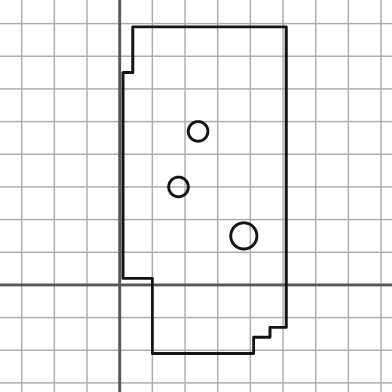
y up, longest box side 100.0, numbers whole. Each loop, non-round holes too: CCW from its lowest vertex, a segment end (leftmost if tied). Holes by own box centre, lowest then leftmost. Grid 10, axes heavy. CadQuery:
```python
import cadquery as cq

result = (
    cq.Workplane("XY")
    .moveTo(10.0, -21.0)
    .lineTo(41.0, -21.0)
    .lineTo(41.0, -16.0)
    .lineTo(46.0, -16.0)
    .lineTo(46.0, -13.0)
    .lineTo(51.0, -13.0)
    .lineTo(51.0, 79.0)
    .lineTo(4.0, 79.0)
    .lineTo(4.0, 65.0)
    .lineTo(1.0, 65.0)
    .lineTo(1.0, 2.0)
    .lineTo(10.0, 2.0)
    .close()
    .moveTo(38.0, 15.0)
    .circle(4.0)
    .moveTo(18.0, 30.0)
    .circle(3.0)
    .moveTo(24.0, 47.0)
    .circle(3.0)
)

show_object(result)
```